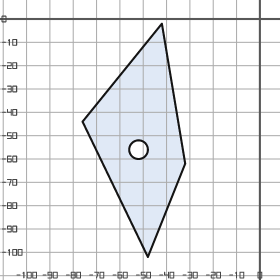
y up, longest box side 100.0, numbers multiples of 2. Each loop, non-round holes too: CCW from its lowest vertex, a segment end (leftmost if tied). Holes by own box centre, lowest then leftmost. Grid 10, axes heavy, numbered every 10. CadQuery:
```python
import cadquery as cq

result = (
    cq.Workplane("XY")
    .moveTo(-48.0, -102.0)
    .lineTo(-32.0, -62.0)
    .lineTo(-42.0, -2.0)
    .lineTo(-76.0, -44.0)
    .close()
    .moveTo(-52.0, -56.0)
    .circle(4.0)
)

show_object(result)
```